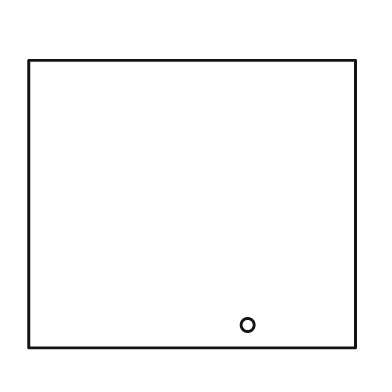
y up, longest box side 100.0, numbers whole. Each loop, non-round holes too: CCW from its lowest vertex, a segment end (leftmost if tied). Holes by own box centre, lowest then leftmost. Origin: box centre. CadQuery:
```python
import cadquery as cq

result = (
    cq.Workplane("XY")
    .moveTo(-50.0, -44.0)
    .lineTo(50.0, -44.0)
    .lineTo(50.0, 44.0)
    .lineTo(-50.0, 44.0)
    .close()
    .moveTo(17.0, -37.0)
    .circle(2.0)
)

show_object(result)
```